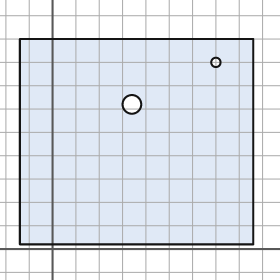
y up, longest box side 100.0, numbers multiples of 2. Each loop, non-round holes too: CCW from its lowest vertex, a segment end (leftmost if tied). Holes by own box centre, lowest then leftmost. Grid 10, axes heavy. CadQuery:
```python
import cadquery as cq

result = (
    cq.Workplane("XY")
    .moveTo(-14.0, 2.0)
    .lineTo(86.0, 2.0)
    .lineTo(86.0, 90.0)
    .lineTo(-14.0, 90.0)
    .close()
    .moveTo(34.0, 62.0)
    .circle(4.0)
    .moveTo(70.0, 80.0)
    .circle(2.0)
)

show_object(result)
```